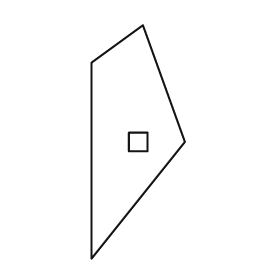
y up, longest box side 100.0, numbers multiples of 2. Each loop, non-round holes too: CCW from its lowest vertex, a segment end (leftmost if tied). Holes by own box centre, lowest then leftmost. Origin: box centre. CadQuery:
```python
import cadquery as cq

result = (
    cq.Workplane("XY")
    .moveTo(-20.0, -50.0)
    .lineTo(20.0, 0.0)
    .lineTo(2.0, 50.0)
    .lineTo(-20.0, 34.0)
    .close()
    .moveTo(-4.0, -4.0)
    .lineTo(4.0, -4.0)
    .lineTo(4.0, 4.0)
    .lineTo(-4.0, 4.0)
    .close()
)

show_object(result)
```